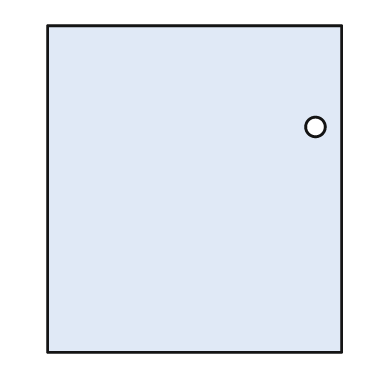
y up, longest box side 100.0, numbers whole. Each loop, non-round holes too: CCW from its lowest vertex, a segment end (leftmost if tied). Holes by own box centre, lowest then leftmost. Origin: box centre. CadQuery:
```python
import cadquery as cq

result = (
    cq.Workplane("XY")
    .moveTo(-45.0, -50.0)
    .lineTo(45.0, -50.0)
    .lineTo(45.0, 50.0)
    .lineTo(-45.0, 50.0)
    .close()
    .moveTo(37.0, 19.0)
    .circle(3.0)
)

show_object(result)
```